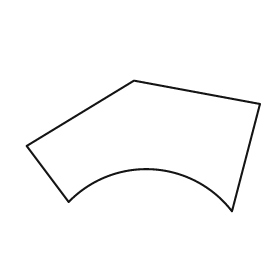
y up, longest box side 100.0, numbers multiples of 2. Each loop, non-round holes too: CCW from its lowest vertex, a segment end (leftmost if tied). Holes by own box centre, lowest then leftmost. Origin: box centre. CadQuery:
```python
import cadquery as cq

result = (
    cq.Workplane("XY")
    .moveTo(38.0, -28.0)
    .lineTo(50.0, 18.0)
    .lineTo(-4.0, 28.0)
    .lineTo(-50.0, 0.0)
    .lineTo(-32.0, -24.0)
    .threePointArc((4.0, -10.0), (38.0, -28.0))
    .close()
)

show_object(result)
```